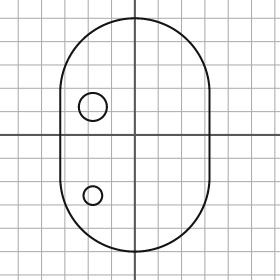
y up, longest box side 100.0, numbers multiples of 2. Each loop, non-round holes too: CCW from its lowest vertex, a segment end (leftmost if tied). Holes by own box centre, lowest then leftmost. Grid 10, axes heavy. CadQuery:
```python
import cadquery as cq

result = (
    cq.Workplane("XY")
    .moveTo(-32.0, -18.0)
    .threePointArc((0.0, -50.0), (32.0, -18.0))
    .lineTo(32.0, 18.0)
    .threePointArc((0.0, 50.0), (-32.0, 18.0))
    .close()
    .moveTo(-18.0, -26.0)
    .circle(4.0)
    .moveTo(-18.0, 12.0)
    .circle(6.0)
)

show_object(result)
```